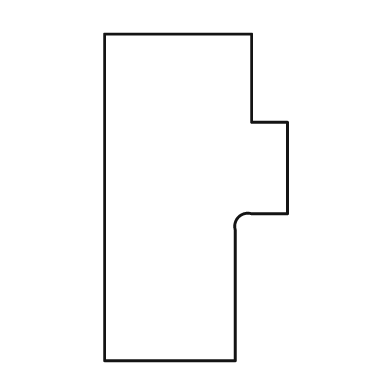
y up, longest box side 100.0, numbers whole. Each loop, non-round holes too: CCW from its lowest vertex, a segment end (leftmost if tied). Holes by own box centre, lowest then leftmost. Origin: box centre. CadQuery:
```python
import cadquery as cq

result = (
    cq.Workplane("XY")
    .moveTo(-28.0, -50.0)
    .lineTo(12.0, -50.0)
    .lineTo(12.0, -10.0)
    .threePointArc((13.0, -6.0), (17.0, -5.0))
    .lineTo(28.0, -5.0)
    .lineTo(28.0, 23.0)
    .lineTo(17.0, 23.0)
    .lineTo(17.0, 50.0)
    .lineTo(-28.0, 50.0)
    .close()
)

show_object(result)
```